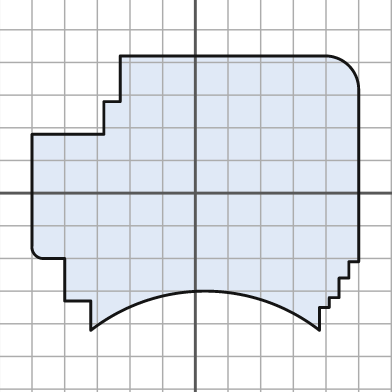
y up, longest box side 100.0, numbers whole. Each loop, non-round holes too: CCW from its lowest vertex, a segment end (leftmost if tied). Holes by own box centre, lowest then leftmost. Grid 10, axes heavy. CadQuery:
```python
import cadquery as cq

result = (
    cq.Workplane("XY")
    .moveTo(-32.0, -42.0)
    .threePointArc((3.0, -30.0), (38.0, -42.0))
    .lineTo(38.0, -35.0)
    .lineTo(41.0, -35.0)
    .lineTo(41.0, -32.0)
    .lineTo(44.0, -32.0)
    .lineTo(44.0, -26.0)
    .lineTo(47.0, -26.0)
    .lineTo(47.0, -21.0)
    .lineTo(50.0, -21.0)
    .lineTo(50.0, 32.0)
    .threePointArc((47.0, 39.0), (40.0, 42.0))
    .lineTo(-23.0, 42.0)
    .lineTo(-23.0, 28.0)
    .lineTo(-28.0, 28.0)
    .lineTo(-28.0, 18.0)
    .lineTo(-50.0, 18.0)
    .lineTo(-50.0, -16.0)
    .threePointArc((-49.0, -19.0), (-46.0, -20.0))
    .lineTo(-40.0, -20.0)
    .lineTo(-40.0, -33.0)
    .lineTo(-32.0, -33.0)
    .close()
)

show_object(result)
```